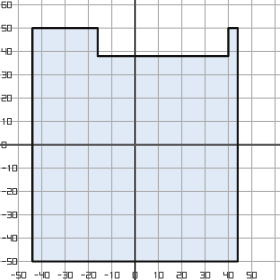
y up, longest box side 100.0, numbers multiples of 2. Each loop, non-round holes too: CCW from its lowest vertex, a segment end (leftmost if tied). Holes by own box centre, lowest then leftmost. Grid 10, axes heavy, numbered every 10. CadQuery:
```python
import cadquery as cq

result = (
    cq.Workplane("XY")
    .moveTo(-44.0, -50.0)
    .lineTo(44.0, -50.0)
    .lineTo(44.0, 50.0)
    .lineTo(40.0, 50.0)
    .lineTo(40.0, 38.0)
    .lineTo(-16.0, 38.0)
    .lineTo(-16.0, 50.0)
    .lineTo(-44.0, 50.0)
    .close()
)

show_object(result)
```